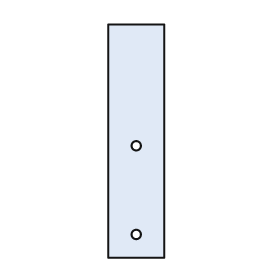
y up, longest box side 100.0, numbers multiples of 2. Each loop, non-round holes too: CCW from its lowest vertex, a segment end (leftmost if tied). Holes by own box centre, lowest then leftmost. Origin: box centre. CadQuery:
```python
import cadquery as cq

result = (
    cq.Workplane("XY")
    .moveTo(-12.0, -50.0)
    .lineTo(12.0, -50.0)
    .lineTo(12.0, 50.0)
    .lineTo(-12.0, 50.0)
    .close()
    .moveTo(0.0, -40.0)
    .circle(2.0)
    .moveTo(0.0, -2.0)
    .circle(2.0)
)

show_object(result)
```